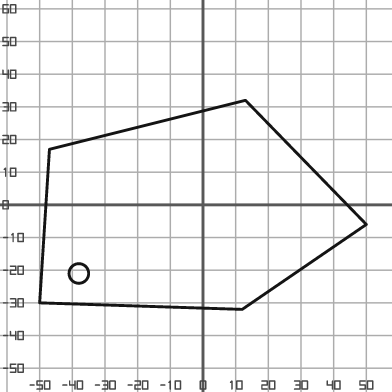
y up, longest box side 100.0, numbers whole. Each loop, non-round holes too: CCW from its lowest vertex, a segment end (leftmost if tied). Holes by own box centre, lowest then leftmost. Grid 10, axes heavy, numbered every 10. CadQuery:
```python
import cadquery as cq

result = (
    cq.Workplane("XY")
    .moveTo(12.0, -32.0)
    .lineTo(50.0, -6.0)
    .lineTo(13.0, 32.0)
    .lineTo(-47.0, 17.0)
    .lineTo(-50.0, -30.0)
    .close()
    .moveTo(-38.0, -21.0)
    .circle(3.0)
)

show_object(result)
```